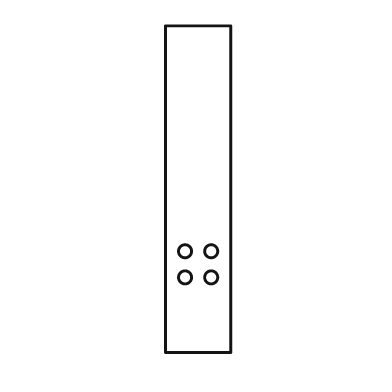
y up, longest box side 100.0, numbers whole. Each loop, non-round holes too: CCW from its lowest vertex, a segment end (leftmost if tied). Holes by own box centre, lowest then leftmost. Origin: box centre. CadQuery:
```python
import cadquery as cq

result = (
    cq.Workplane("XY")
    .moveTo(-10.0, -50.0)
    .lineTo(10.0, -50.0)
    .lineTo(10.0, 50.0)
    .lineTo(-10.0, 50.0)
    .close()
    .moveTo(-4.0, -27.0)
    .circle(2.0)
    .moveTo(4.0, -27.0)
    .circle(2.0)
    .moveTo(-4.0, -19.0)
    .circle(2.0)
    .moveTo(4.0, -19.0)
    .circle(2.0)
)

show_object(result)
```